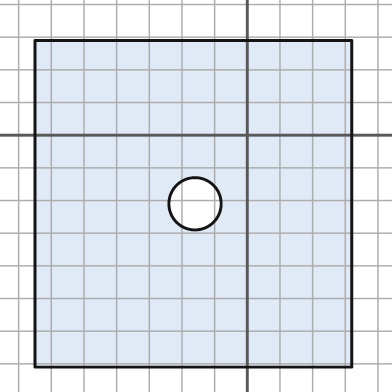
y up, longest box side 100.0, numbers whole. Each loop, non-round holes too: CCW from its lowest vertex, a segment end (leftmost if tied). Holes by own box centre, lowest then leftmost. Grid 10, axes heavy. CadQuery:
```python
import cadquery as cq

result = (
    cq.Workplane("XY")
    .moveTo(-65.0, -71.0)
    .lineTo(32.0, -71.0)
    .lineTo(32.0, 29.0)
    .lineTo(-65.0, 29.0)
    .close()
    .moveTo(-16.0, -21.0)
    .circle(8.0)
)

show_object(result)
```